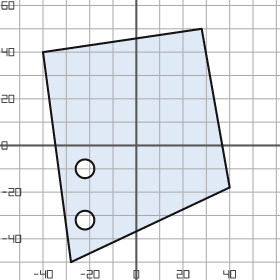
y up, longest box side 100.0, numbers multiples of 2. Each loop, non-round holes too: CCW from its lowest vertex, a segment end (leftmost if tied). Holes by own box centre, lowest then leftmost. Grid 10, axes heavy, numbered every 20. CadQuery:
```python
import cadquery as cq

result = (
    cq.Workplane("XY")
    .moveTo(-28.0, -50.0)
    .lineTo(40.0, -18.0)
    .lineTo(28.0, 50.0)
    .lineTo(-40.0, 40.0)
    .close()
    .moveTo(-22.0, -32.0)
    .circle(4.0)
    .moveTo(-22.0, -10.0)
    .circle(4.0)
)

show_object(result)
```